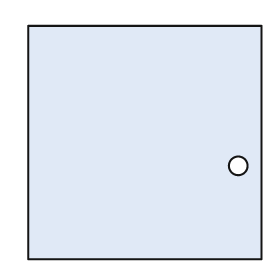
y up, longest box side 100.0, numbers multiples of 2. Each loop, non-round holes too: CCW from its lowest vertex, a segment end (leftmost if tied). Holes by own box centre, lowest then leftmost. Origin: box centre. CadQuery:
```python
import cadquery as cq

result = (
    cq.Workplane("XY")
    .moveTo(-50.0, -50.0)
    .lineTo(50.0, -50.0)
    .lineTo(50.0, 50.0)
    .lineTo(-50.0, 50.0)
    .close()
    .moveTo(40.0, -10.0)
    .circle(4.0)
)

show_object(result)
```